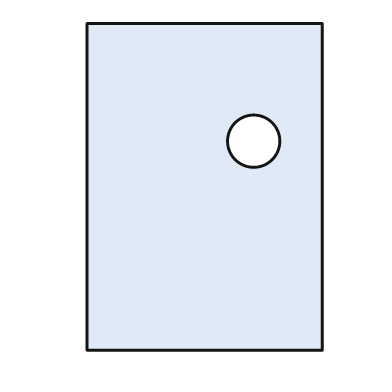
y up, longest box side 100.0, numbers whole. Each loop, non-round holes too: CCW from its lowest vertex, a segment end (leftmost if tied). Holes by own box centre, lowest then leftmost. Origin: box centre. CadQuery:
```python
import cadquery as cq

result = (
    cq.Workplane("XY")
    .moveTo(-36.0, -50.0)
    .lineTo(36.0, -50.0)
    .lineTo(36.0, 50.0)
    .lineTo(-36.0, 50.0)
    .close()
    .moveTo(15.0, 14.0)
    .circle(8.0)
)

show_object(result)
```